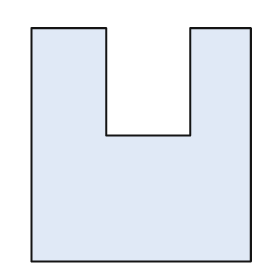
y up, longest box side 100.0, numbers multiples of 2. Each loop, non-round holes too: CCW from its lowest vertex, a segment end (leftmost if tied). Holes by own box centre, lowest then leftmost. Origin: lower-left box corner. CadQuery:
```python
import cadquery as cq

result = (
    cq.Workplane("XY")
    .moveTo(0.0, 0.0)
    .lineTo(94.0, 0.0)
    .lineTo(94.0, 100.0)
    .lineTo(68.0, 100.0)
    .lineTo(68.0, 54.0)
    .lineTo(32.0, 54.0)
    .lineTo(32.0, 100.0)
    .lineTo(0.0, 100.0)
    .close()
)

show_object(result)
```